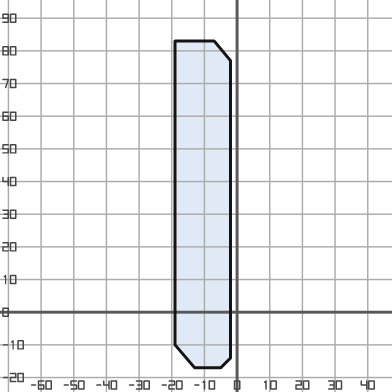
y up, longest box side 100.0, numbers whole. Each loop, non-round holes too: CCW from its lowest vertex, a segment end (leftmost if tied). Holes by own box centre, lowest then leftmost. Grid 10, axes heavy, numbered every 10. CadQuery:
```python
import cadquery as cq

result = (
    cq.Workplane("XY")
    .moveTo(-13.0, -17.0)
    .lineTo(-5.0, -17.0)
    .lineTo(-2.0, -14.0)
    .lineTo(-2.0, 77.0)
    .lineTo(-7.0, 83.0)
    .lineTo(-19.0, 83.0)
    .lineTo(-19.0, -10.0)
    .close()
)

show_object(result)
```